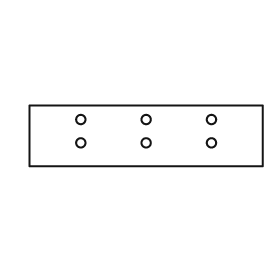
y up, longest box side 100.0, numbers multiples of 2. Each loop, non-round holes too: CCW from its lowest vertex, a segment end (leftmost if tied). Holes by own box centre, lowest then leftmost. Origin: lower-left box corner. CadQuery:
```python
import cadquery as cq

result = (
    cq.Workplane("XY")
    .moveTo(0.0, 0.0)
    .lineTo(100.0, 0.0)
    .lineTo(100.0, 26.0)
    .lineTo(0.0, 26.0)
    .close()
    .moveTo(22.0, 10.0)
    .circle(2.0)
    .moveTo(50.0, 10.0)
    .circle(2.0)
    .moveTo(78.0, 10.0)
    .circle(2.0)
    .moveTo(22.0, 20.0)
    .circle(2.0)
    .moveTo(50.0, 20.0)
    .circle(2.0)
    .moveTo(78.0, 20.0)
    .circle(2.0)
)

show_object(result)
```